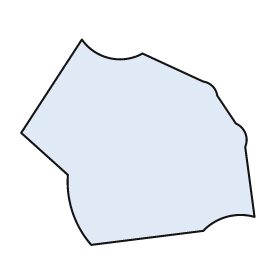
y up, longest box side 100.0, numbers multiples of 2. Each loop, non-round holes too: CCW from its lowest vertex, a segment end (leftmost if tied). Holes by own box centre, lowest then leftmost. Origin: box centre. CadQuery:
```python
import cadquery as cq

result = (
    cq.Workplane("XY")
    .moveTo(-20.0, -44.0)
    .lineTo(28.0, -38.0)
    .threePointArc((38.0, -32.0), (50.0, -32.0))
    .lineTo(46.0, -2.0)
    .threePointArc((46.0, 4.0), (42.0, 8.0))
    .lineTo(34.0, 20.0)
    .threePointArc((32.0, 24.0), (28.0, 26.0))
    .lineTo(2.0, 38.0)
    .threePointArc((-12.0, 36.0), (-24.0, 44.0))
    .lineTo(-50.0, 4.0)
    .lineTo(-30.0, -14.0)
    .threePointArc((-28.0, -30.0), (-20.0, -44.0))
    .close()
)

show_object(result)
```